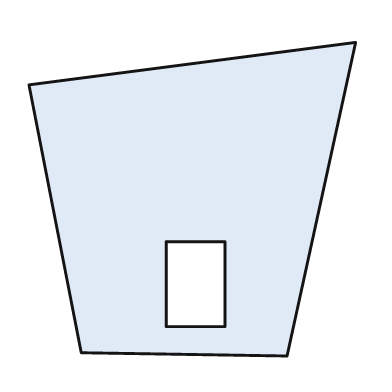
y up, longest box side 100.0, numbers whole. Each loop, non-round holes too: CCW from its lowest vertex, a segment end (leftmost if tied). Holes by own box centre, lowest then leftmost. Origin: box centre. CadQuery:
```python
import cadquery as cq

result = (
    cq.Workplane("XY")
    .moveTo(29.0, -48.0)
    .lineTo(50.0, 48.0)
    .lineTo(-50.0, 35.0)
    .lineTo(-34.0, -47.0)
    .close()
    .moveTo(-8.0, -39.0)
    .lineTo(10.0, -39.0)
    .lineTo(10.0, -13.0)
    .lineTo(-8.0, -13.0)
    .close()
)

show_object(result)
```